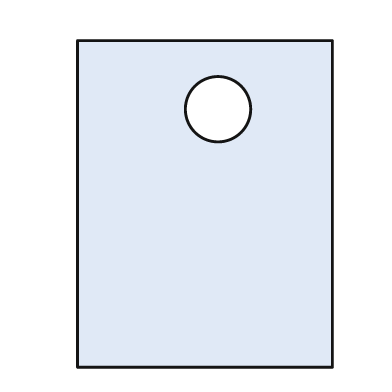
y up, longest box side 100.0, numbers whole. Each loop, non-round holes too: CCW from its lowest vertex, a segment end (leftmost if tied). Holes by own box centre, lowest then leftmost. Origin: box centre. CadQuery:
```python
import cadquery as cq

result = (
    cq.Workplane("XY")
    .moveTo(-39.0, -50.0)
    .lineTo(39.0, -50.0)
    .lineTo(39.0, 50.0)
    .lineTo(-39.0, 50.0)
    .close()
    .moveTo(4.0, 29.0)
    .circle(10.0)
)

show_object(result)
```